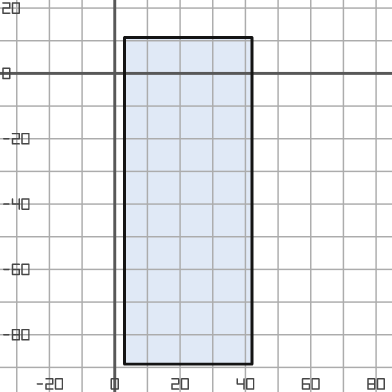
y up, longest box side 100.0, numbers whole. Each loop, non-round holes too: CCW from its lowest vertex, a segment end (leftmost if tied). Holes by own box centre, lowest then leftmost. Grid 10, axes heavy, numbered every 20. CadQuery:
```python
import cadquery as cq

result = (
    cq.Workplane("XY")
    .moveTo(3.0, -89.0)
    .lineTo(42.0, -89.0)
    .lineTo(42.0, 11.0)
    .lineTo(3.0, 11.0)
    .close()
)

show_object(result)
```